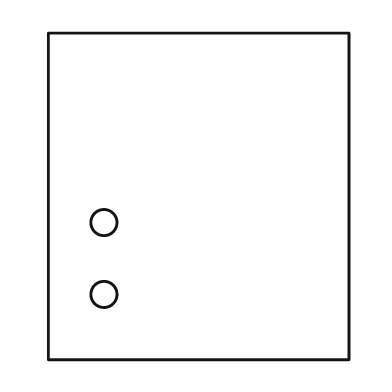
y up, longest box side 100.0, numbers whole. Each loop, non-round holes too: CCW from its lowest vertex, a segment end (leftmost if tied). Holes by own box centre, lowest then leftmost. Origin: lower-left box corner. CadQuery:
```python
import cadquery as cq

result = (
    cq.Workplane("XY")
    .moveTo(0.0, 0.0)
    .lineTo(92.0, 0.0)
    .lineTo(92.0, 100.0)
    .lineTo(0.0, 100.0)
    .close()
    .moveTo(17.0, 20.0)
    .circle(4.0)
    .moveTo(17.0, 42.0)
    .circle(4.0)
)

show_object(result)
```